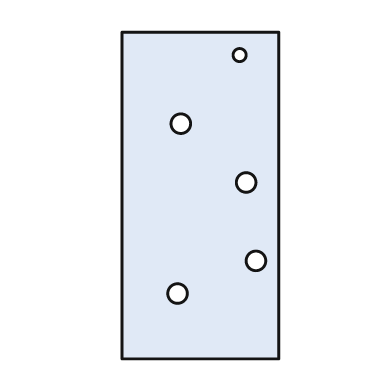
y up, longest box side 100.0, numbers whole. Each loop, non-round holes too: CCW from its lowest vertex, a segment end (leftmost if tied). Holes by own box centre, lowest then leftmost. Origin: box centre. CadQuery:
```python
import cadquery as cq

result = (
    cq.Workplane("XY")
    .moveTo(-24.0, -50.0)
    .lineTo(24.0, -50.0)
    .lineTo(24.0, 50.0)
    .lineTo(-24.0, 50.0)
    .close()
    .moveTo(-7.0, -30.0)
    .circle(3.0)
    .moveTo(17.0, -20.0)
    .circle(3.0)
    .moveTo(14.0, 4.0)
    .circle(3.0)
    .moveTo(-6.0, 22.0)
    .circle(3.0)
    .moveTo(12.0, 43.0)
    .circle(2.0)
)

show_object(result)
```